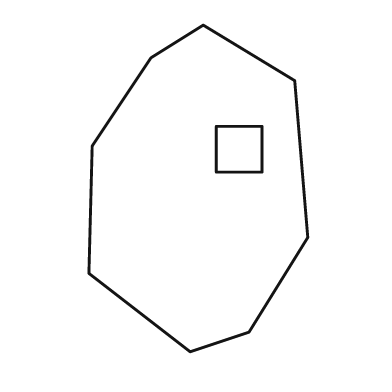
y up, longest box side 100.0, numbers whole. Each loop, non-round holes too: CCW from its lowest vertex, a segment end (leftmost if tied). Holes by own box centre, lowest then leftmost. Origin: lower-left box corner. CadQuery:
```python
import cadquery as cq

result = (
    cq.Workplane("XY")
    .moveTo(31.0, 0.0)
    .lineTo(49.0, 6.0)
    .lineTo(67.0, 35.0)
    .lineTo(63.0, 83.0)
    .lineTo(35.0, 100.0)
    .lineTo(19.0, 90.0)
    .lineTo(1.0, 63.0)
    .lineTo(0.0, 24.0)
    .close()
    .moveTo(39.0, 55.0)
    .lineTo(53.0, 55.0)
    .lineTo(53.0, 69.0)
    .lineTo(39.0, 69.0)
    .close()
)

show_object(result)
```